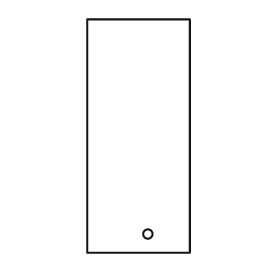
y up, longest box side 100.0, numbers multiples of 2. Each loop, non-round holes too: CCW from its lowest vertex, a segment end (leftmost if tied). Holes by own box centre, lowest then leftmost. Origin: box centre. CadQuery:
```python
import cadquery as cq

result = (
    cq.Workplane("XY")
    .moveTo(-22.0, -50.0)
    .lineTo(22.0, -50.0)
    .lineTo(22.0, 50.0)
    .lineTo(-22.0, 50.0)
    .close()
    .moveTo(4.0, -42.0)
    .circle(2.0)
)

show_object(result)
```